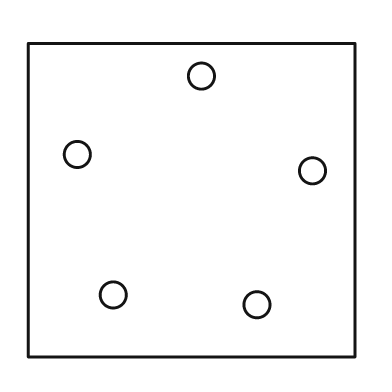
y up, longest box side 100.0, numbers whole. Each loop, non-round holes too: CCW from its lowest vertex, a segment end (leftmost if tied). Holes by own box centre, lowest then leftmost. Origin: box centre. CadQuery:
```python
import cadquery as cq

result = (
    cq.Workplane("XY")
    .moveTo(-50.0, -48.0)
    .lineTo(50.0, -48.0)
    .lineTo(50.0, 48.0)
    .lineTo(-50.0, 48.0)
    .close()
    .moveTo(20.0, -32.0)
    .circle(4.0)
    .moveTo(-24.0, -29.0)
    .circle(4.0)
    .moveTo(37.0, 9.0)
    .circle(4.0)
    .moveTo(-35.0, 14.0)
    .circle(4.0)
    .moveTo(3.0, 38.0)
    .circle(4.0)
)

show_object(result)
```